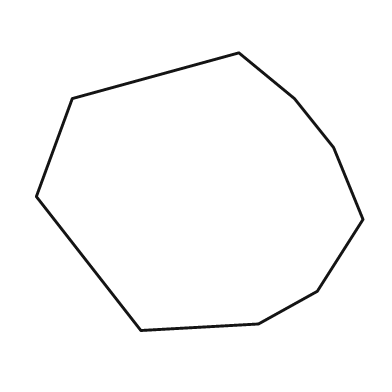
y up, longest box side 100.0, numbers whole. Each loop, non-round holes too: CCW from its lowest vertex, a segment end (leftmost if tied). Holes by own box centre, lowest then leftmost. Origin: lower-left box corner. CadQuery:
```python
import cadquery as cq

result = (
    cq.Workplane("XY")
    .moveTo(32.0, 0.0)
    .lineTo(68.0, 2.0)
    .lineTo(86.0, 12.0)
    .lineTo(100.0, 34.0)
    .lineTo(91.0, 56.0)
    .lineTo(79.0, 71.0)
    .lineTo(62.0, 85.0)
    .lineTo(11.0, 71.0)
    .lineTo(0.0, 41.0)
    .close()
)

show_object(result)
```